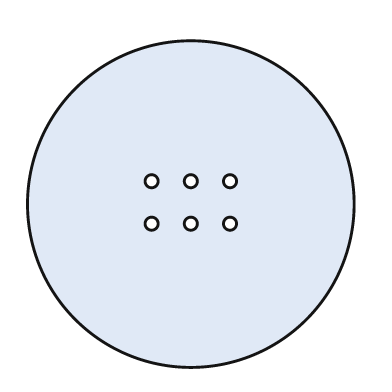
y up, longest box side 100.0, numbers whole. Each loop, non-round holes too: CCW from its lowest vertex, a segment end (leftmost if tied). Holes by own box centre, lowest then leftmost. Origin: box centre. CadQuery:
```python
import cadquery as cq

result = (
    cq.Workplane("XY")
    .moveTo(0.0, 0.0)
    .circle(50.0)
    .moveTo(-12.0, -6.0)
    .circle(2.0)
    .moveTo(0.0, -6.0)
    .circle(2.0)
    .moveTo(12.0, -6.0)
    .circle(2.0)
    .moveTo(-12.0, 7.0)
    .circle(2.0)
    .moveTo(0.0, 7.0)
    .circle(2.0)
    .moveTo(12.0, 7.0)
    .circle(2.0)
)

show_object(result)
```